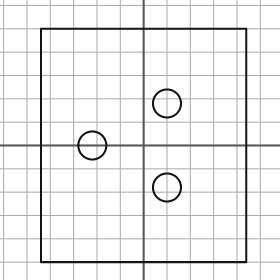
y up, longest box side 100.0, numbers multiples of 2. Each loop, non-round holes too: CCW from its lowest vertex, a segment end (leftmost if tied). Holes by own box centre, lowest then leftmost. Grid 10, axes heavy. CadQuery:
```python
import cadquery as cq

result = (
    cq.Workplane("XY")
    .moveTo(-44.0, -50.0)
    .lineTo(44.0, -50.0)
    .lineTo(44.0, 50.0)
    .lineTo(-44.0, 50.0)
    .close()
    .moveTo(10.0, -18.0)
    .circle(6.0)
    .moveTo(-22.0, 0.0)
    .circle(6.0)
    .moveTo(10.0, 18.0)
    .circle(6.0)
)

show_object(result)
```